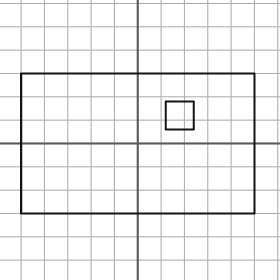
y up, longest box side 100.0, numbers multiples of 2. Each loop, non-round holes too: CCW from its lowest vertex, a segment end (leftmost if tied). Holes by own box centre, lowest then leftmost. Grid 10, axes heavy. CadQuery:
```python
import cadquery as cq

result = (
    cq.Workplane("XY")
    .moveTo(-50.0, -30.0)
    .lineTo(50.0, -30.0)
    .lineTo(50.0, 30.0)
    .lineTo(-50.0, 30.0)
    .close()
    .moveTo(12.0, 6.0)
    .lineTo(24.0, 6.0)
    .lineTo(24.0, 18.0)
    .lineTo(12.0, 18.0)
    .close()
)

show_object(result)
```